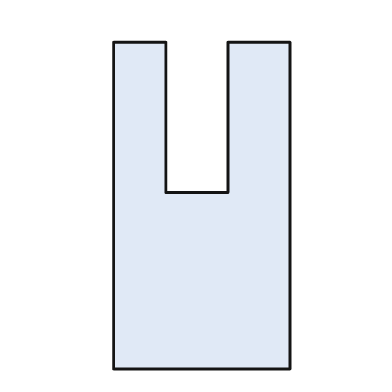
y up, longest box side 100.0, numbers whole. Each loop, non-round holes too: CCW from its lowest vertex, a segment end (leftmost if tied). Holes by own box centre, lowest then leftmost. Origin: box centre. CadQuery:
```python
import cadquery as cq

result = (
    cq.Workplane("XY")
    .moveTo(-27.0, -50.0)
    .lineTo(27.0, -50.0)
    .lineTo(27.0, 50.0)
    .lineTo(8.0, 50.0)
    .lineTo(8.0, 4.0)
    .lineTo(-11.0, 4.0)
    .lineTo(-11.0, 50.0)
    .lineTo(-27.0, 50.0)
    .close()
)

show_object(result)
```